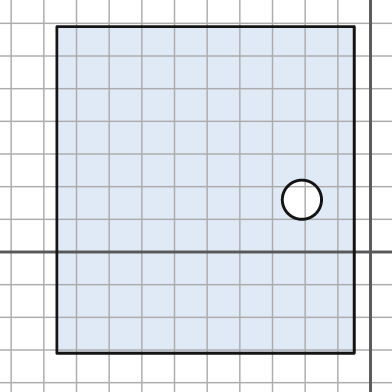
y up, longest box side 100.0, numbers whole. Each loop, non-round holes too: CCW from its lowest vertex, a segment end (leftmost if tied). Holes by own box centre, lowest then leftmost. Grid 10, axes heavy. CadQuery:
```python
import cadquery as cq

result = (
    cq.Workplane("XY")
    .moveTo(-96.0, -31.0)
    .lineTo(-5.0, -31.0)
    .lineTo(-5.0, 69.0)
    .lineTo(-96.0, 69.0)
    .close()
    .moveTo(-21.0, 16.0)
    .circle(6.0)
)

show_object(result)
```